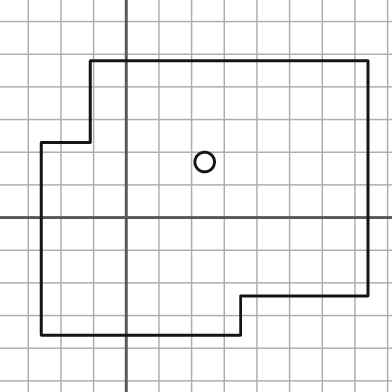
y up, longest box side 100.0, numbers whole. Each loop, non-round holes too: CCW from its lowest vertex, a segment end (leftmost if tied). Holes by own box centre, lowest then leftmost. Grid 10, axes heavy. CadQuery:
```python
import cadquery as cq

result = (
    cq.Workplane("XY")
    .moveTo(-26.0, -36.0)
    .lineTo(35.0, -36.0)
    .lineTo(35.0, -24.0)
    .lineTo(74.0, -24.0)
    .lineTo(74.0, 48.0)
    .lineTo(-11.0, 48.0)
    .lineTo(-11.0, 23.0)
    .lineTo(-26.0, 23.0)
    .close()
    .moveTo(24.0, 17.0)
    .circle(3.0)
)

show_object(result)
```